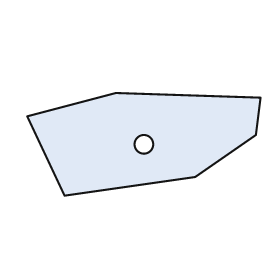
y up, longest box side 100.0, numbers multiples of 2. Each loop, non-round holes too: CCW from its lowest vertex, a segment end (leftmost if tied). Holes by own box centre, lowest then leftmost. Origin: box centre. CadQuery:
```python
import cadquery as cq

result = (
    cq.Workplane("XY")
    .moveTo(-34.0, -22.0)
    .lineTo(22.0, -14.0)
    .lineTo(48.0, 4.0)
    .lineTo(50.0, 20.0)
    .lineTo(-12.0, 22.0)
    .lineTo(-50.0, 12.0)
    .close()
    .moveTo(0.0, 0.0)
    .circle(4.0)
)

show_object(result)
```